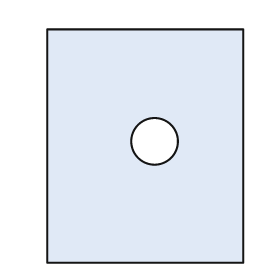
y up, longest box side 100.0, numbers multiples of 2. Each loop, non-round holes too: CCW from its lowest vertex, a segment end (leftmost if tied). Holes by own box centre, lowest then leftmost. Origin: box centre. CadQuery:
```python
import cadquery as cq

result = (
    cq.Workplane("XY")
    .moveTo(-42.0, -50.0)
    .lineTo(42.0, -50.0)
    .lineTo(42.0, 50.0)
    .lineTo(-42.0, 50.0)
    .close()
    .moveTo(4.0, 2.0)
    .circle(10.0)
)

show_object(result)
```